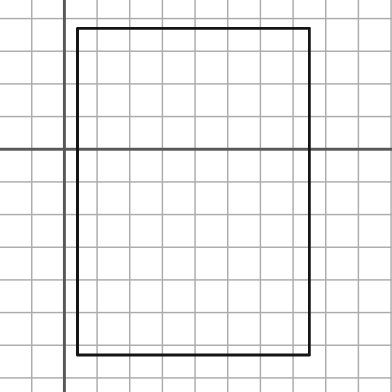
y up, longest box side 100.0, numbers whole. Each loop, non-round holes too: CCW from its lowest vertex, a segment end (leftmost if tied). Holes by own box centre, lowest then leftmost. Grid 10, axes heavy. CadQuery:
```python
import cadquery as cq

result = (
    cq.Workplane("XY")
    .moveTo(4.0, -63.0)
    .lineTo(75.0, -63.0)
    .lineTo(75.0, 37.0)
    .lineTo(4.0, 37.0)
    .close()
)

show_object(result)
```